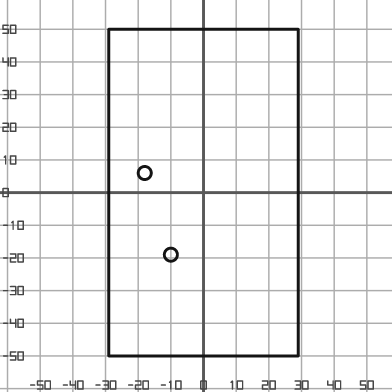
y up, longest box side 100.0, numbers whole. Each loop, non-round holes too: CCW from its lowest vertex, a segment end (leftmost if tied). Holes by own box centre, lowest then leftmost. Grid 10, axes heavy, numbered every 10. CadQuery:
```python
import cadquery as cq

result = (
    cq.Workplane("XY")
    .moveTo(-29.0, -50.0)
    .lineTo(29.0, -50.0)
    .lineTo(29.0, 50.0)
    .lineTo(-29.0, 50.0)
    .close()
    .moveTo(-10.0, -19.0)
    .circle(2.0)
    .moveTo(-18.0, 6.0)
    .circle(2.0)
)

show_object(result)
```